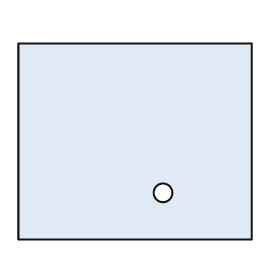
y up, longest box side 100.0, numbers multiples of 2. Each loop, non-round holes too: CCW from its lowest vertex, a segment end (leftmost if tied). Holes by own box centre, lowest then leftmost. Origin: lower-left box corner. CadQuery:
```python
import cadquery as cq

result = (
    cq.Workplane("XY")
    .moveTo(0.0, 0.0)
    .lineTo(100.0, 0.0)
    .lineTo(100.0, 84.0)
    .lineTo(0.0, 84.0)
    .close()
    .moveTo(62.0, 20.0)
    .circle(4.0)
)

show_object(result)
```